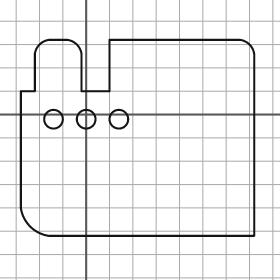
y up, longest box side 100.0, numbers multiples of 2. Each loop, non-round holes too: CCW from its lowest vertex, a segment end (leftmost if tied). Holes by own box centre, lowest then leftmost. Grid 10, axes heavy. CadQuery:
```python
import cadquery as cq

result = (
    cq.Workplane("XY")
    .moveTo(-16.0, -52.0)
    .lineTo(72.0, -52.0)
    .lineTo(72.0, 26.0)
    .threePointArc((70.0, 30.0), (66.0, 32.0))
    .lineTo(10.0, 32.0)
    .lineTo(10.0, 10.0)
    .lineTo(-2.0, 10.0)
    .lineTo(-2.0, 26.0)
    .threePointArc((-4.0, 30.0), (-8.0, 32.0))
    .lineTo(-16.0, 32.0)
    .threePointArc((-20.0, 30.0), (-22.0, 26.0))
    .lineTo(-22.0, 10.0)
    .lineTo(-28.0, 10.0)
    .lineTo(-28.0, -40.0)
    .threePointArc((-24.0, -48.0), (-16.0, -52.0))
    .close()
    .moveTo(-14.0, -2.0)
    .circle(4.0)
    .moveTo(0.0, -2.0)
    .circle(4.0)
    .moveTo(14.0, -2.0)
    .circle(4.0)
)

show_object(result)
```